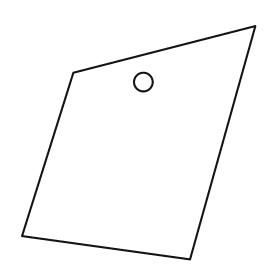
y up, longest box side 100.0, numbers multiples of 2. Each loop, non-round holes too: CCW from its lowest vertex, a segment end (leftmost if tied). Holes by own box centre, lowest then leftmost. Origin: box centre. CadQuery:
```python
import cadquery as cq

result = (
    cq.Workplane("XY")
    .moveTo(22.0, -50.0)
    .lineTo(50.0, 50.0)
    .lineTo(-28.0, 30.0)
    .lineTo(-50.0, -40.0)
    .close()
    .moveTo(2.0, 26.0)
    .circle(4.0)
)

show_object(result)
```